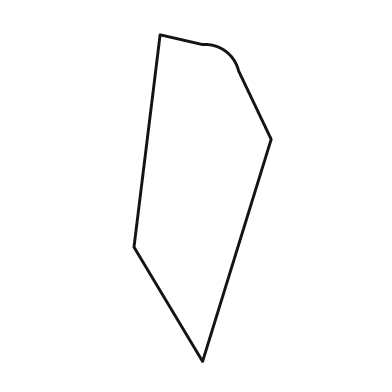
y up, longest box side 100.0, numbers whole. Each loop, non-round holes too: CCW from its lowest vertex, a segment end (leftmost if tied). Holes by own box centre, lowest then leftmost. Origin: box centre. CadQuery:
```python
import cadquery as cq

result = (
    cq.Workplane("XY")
    .moveTo(0.0, -50.0)
    .lineTo(21.0, 18.0)
    .lineTo(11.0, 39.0)
    .threePointArc((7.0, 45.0), (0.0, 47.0))
    .lineTo(-13.0, 50.0)
    .lineTo(-21.0, -15.0)
    .close()
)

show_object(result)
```